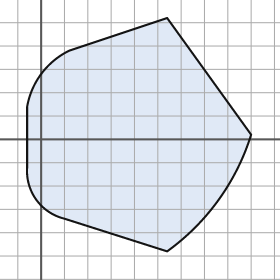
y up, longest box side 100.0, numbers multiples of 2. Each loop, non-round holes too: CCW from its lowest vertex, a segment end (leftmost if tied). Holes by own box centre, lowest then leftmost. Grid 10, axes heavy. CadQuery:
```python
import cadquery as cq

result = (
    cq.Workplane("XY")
    .moveTo(54.0, -48.0)
    .threePointArc((76.0, -26.0), (90.0, 2.0))
    .lineTo(54.0, 52.0)
    .lineTo(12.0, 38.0)
    .threePointArc((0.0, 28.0), (-6.0, 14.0))
    .lineTo(-6.0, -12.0)
    .threePointArc((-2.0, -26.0), (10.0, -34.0))
    .close()
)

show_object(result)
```